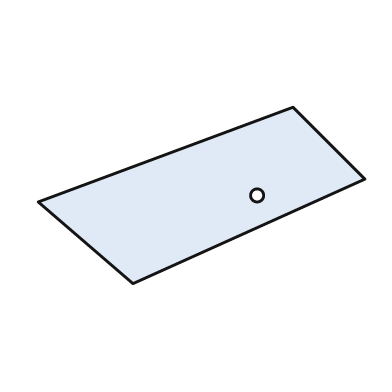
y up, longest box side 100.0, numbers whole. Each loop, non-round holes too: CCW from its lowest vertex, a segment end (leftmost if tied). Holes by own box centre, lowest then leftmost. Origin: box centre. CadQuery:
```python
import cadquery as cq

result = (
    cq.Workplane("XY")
    .moveTo(-21.0, -27.0)
    .lineTo(50.0, 5.0)
    .lineTo(28.0, 27.0)
    .lineTo(-50.0, -2.0)
    .close()
    .moveTo(17.0, 0.0)
    .circle(2.0)
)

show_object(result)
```